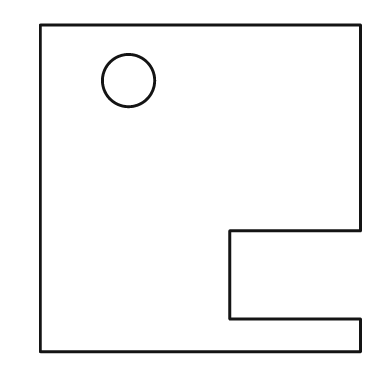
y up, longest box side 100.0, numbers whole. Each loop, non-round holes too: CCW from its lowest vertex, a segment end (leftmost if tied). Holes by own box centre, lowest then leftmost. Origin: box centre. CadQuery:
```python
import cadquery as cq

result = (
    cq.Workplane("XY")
    .moveTo(-49.0, -50.0)
    .lineTo(49.0, -50.0)
    .lineTo(49.0, -40.0)
    .lineTo(9.0, -40.0)
    .lineTo(9.0, -13.0)
    .lineTo(49.0, -13.0)
    .lineTo(49.0, 50.0)
    .lineTo(-49.0, 50.0)
    .close()
    .moveTo(-22.0, 33.0)
    .circle(8.0)
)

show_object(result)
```